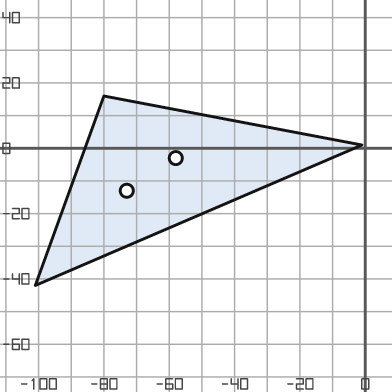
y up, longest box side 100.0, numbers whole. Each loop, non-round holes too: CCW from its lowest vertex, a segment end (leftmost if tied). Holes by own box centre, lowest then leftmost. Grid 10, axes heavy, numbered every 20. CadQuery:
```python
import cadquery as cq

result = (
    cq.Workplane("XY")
    .moveTo(-101.0, -42.0)
    .lineTo(-1.0, 1.0)
    .lineTo(-80.0, 16.0)
    .close()
    .moveTo(-73.0, -13.0)
    .circle(2.0)
    .moveTo(-58.0, -3.0)
    .circle(2.0)
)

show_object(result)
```